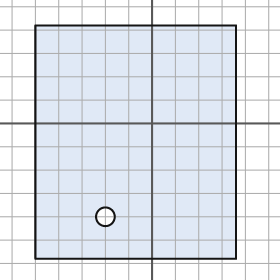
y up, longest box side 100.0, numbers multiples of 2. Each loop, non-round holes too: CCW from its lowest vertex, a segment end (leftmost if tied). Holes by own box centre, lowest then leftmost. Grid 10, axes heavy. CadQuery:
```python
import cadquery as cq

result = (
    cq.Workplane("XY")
    .moveTo(-50.0, -58.0)
    .lineTo(36.0, -58.0)
    .lineTo(36.0, 42.0)
    .lineTo(-50.0, 42.0)
    .close()
    .moveTo(-20.0, -40.0)
    .circle(4.0)
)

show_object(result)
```